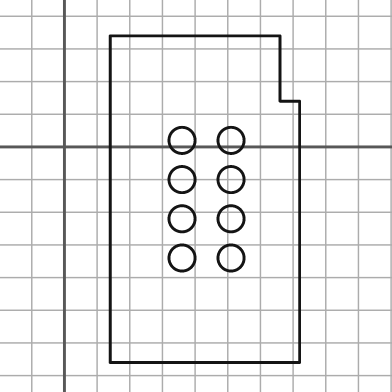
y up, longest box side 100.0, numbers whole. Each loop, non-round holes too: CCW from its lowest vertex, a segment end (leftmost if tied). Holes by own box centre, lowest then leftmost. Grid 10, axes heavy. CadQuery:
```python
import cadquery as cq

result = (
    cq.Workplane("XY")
    .moveTo(14.0, -66.0)
    .lineTo(72.0, -66.0)
    .lineTo(72.0, 14.0)
    .lineTo(66.0, 14.0)
    .lineTo(66.0, 34.0)
    .lineTo(14.0, 34.0)
    .close()
    .moveTo(36.0, -34.0)
    .circle(4.0)
    .moveTo(51.0, -34.0)
    .circle(4.0)
    .moveTo(36.0, -22.0)
    .circle(4.0)
    .moveTo(51.0, -22.0)
    .circle(4.0)
    .moveTo(36.0, -10.0)
    .circle(4.0)
    .moveTo(51.0, -10.0)
    .circle(4.0)
    .moveTo(36.0, 2.0)
    .circle(4.0)
    .moveTo(51.0, 2.0)
    .circle(4.0)
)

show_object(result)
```